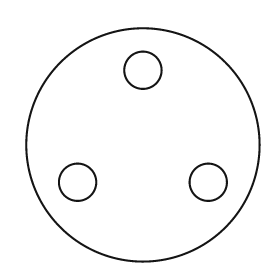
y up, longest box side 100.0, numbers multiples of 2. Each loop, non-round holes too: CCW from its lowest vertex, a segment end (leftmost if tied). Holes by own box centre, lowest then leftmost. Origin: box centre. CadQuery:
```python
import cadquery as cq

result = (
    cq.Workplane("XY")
    .moveTo(0.0, 0.0)
    .circle(50.0)
    .moveTo(-28.0, -16.0)
    .circle(8.0)
    .moveTo(28.0, -16.0)
    .circle(8.0)
    .moveTo(0.0, 32.0)
    .circle(8.0)
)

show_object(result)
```